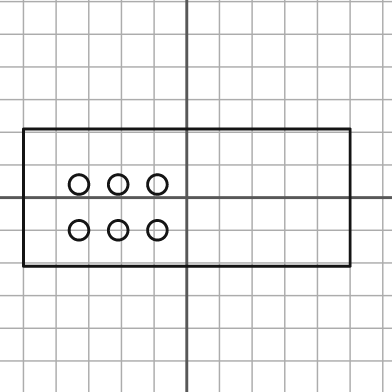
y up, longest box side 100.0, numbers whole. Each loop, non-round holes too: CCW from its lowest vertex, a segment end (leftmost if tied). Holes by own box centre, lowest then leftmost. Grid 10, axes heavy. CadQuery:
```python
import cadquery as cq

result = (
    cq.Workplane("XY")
    .moveTo(-50.0, -21.0)
    .lineTo(50.0, -21.0)
    .lineTo(50.0, 21.0)
    .lineTo(-50.0, 21.0)
    .close()
    .moveTo(-33.0, -10.0)
    .circle(3.0)
    .moveTo(-21.0, -10.0)
    .circle(3.0)
    .moveTo(-9.0, -10.0)
    .circle(3.0)
    .moveTo(-33.0, 4.0)
    .circle(3.0)
    .moveTo(-21.0, 4.0)
    .circle(3.0)
    .moveTo(-9.0, 4.0)
    .circle(3.0)
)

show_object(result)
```